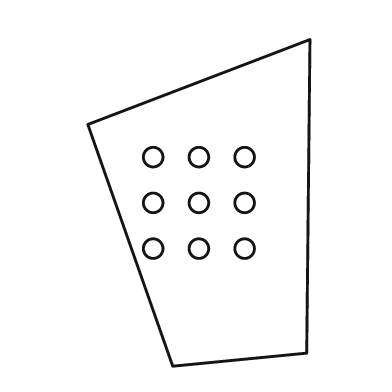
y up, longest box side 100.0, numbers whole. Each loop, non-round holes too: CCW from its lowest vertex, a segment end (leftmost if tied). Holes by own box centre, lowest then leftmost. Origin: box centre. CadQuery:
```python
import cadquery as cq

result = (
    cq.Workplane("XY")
    .moveTo(-8.0, -50.0)
    .lineTo(33.0, -46.0)
    .lineTo(34.0, 50.0)
    .lineTo(-34.0, 24.0)
    .close()
    .moveTo(-14.0, -14.0)
    .circle(3.0)
    .moveTo(0.0, -14.0)
    .circle(3.0)
    .moveTo(14.0, -14.0)
    .circle(3.0)
    .moveTo(-14.0, 0.0)
    .circle(3.0)
    .moveTo(0.0, 0.0)
    .circle(3.0)
    .moveTo(14.0, 0.0)
    .circle(3.0)
    .moveTo(-14.0, 14.0)
    .circle(3.0)
    .moveTo(0.0, 14.0)
    .circle(3.0)
    .moveTo(14.0, 14.0)
    .circle(3.0)
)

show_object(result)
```